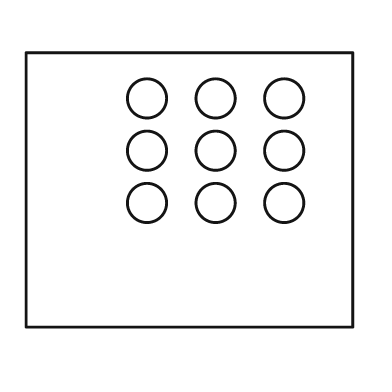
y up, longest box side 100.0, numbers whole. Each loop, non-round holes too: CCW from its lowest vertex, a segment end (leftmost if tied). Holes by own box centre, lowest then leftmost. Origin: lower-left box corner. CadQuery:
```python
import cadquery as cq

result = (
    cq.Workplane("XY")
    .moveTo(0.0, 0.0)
    .lineTo(100.0, 0.0)
    .lineTo(100.0, 84.0)
    .lineTo(0.0, 84.0)
    .close()
    .moveTo(37.0, 38.0)
    .circle(6.0)
    .moveTo(58.0, 38.0)
    .circle(6.0)
    .moveTo(79.0, 38.0)
    .circle(6.0)
    .moveTo(37.0, 54.0)
    .circle(6.0)
    .moveTo(58.0, 54.0)
    .circle(6.0)
    .moveTo(79.0, 54.0)
    .circle(6.0)
    .moveTo(37.0, 70.0)
    .circle(6.0)
    .moveTo(58.0, 70.0)
    .circle(6.0)
    .moveTo(79.0, 70.0)
    .circle(6.0)
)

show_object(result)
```